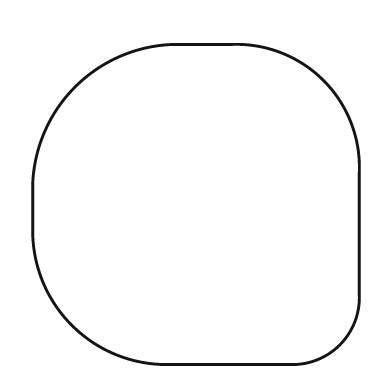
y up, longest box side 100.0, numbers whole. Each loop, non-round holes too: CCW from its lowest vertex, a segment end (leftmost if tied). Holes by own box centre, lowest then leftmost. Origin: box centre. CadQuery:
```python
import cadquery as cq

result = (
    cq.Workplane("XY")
    .moveTo(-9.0, -49.0)
    .lineTo(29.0, -49.0)
    .threePointArc((44.0, -43.0), (50.0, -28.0))
    .lineTo(50.0, 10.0)
    .threePointArc((39.0, 38.0), (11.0, 49.0))
    .lineTo(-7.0, 49.0)
    .threePointArc((-37.0, 36.0), (-50.0, 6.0))
    .lineTo(-50.0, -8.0)
    .threePointArc((-38.0, -37.0), (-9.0, -49.0))
    .close()
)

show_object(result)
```